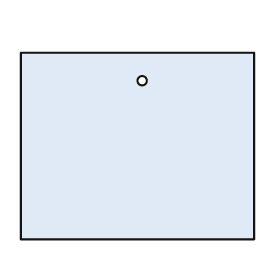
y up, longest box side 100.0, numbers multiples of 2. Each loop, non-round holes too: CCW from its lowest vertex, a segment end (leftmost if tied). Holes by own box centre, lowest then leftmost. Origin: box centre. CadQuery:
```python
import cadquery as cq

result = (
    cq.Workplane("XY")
    .moveTo(-50.0, -40.0)
    .lineTo(50.0, -40.0)
    .lineTo(50.0, 40.0)
    .lineTo(-50.0, 40.0)
    .close()
    .moveTo(2.0, 28.0)
    .circle(2.0)
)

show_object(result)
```